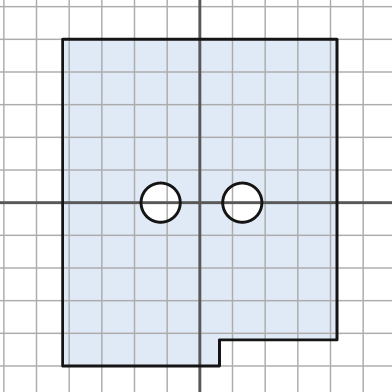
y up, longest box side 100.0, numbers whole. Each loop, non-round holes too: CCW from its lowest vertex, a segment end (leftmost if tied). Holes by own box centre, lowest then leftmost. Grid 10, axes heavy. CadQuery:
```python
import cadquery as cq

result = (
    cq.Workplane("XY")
    .moveTo(-42.0, -50.0)
    .lineTo(6.0, -50.0)
    .lineTo(6.0, -42.0)
    .lineTo(42.0, -42.0)
    .lineTo(42.0, 50.0)
    .lineTo(-42.0, 50.0)
    .close()
    .moveTo(-12.0, 0.0)
    .circle(6.0)
    .moveTo(13.0, 0.0)
    .circle(6.0)
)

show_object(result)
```